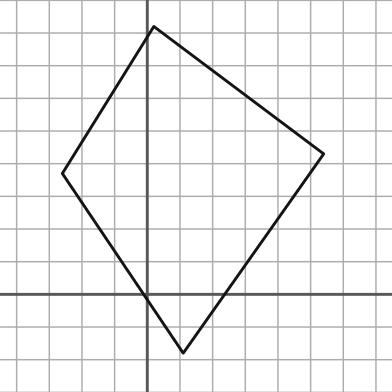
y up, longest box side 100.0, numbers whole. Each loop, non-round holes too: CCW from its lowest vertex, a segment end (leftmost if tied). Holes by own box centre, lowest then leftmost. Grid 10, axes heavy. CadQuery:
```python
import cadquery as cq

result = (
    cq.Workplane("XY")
    .moveTo(11.0, -18.0)
    .lineTo(54.0, 43.0)
    .lineTo(2.0, 82.0)
    .lineTo(-26.0, 37.0)
    .close()
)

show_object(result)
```